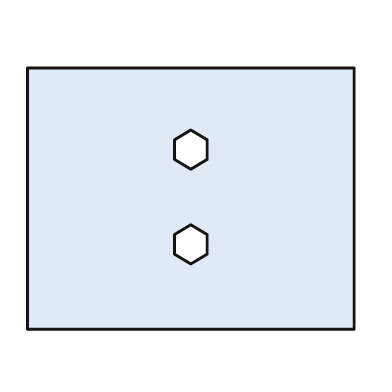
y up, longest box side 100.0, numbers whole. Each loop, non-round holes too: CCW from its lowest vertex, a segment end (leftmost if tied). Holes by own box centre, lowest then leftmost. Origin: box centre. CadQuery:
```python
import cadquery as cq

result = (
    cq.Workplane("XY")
    .moveTo(-50.0, -40.0)
    .lineTo(50.0, -40.0)
    .lineTo(50.0, 40.0)
    .lineTo(-50.0, 40.0)
    .close()
    .moveTo(0.0, -20.0)
    .lineTo(5.0, -17.0)
    .lineTo(5.0, -11.0)
    .lineTo(0.0, -8.0)
    .lineTo(-5.0, -11.0)
    .lineTo(-5.0, -17.0)
    .close()
    .moveTo(0.0, 9.0)
    .lineTo(5.0, 12.0)
    .lineTo(5.0, 18.0)
    .lineTo(0.0, 21.0)
    .lineTo(-5.0, 18.0)
    .lineTo(-5.0, 12.0)
    .close()
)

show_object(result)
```